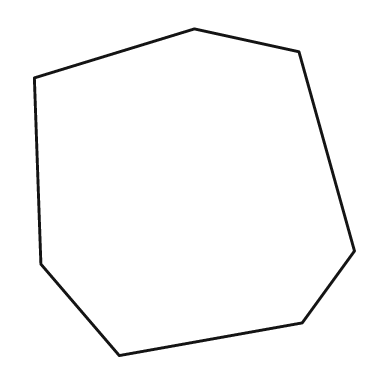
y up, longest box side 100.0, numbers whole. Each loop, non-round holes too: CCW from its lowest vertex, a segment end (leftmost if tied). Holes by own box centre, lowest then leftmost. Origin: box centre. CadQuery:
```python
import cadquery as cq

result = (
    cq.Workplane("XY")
    .moveTo(-23.0, -50.0)
    .lineTo(33.0, -40.0)
    .lineTo(49.0, -18.0)
    .lineTo(32.0, 43.0)
    .lineTo(0.0, 50.0)
    .lineTo(-49.0, 35.0)
    .lineTo(-47.0, -22.0)
    .close()
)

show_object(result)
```